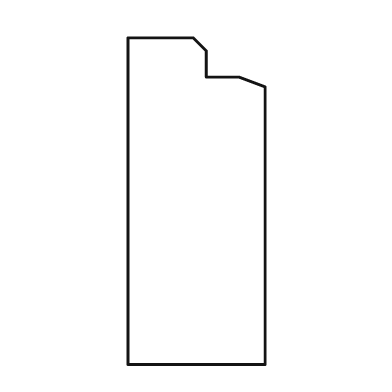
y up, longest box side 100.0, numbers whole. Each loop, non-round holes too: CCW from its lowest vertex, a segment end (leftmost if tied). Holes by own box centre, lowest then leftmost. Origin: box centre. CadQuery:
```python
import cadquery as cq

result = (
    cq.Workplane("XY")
    .moveTo(-21.0, -50.0)
    .lineTo(21.0, -50.0)
    .lineTo(21.0, 35.0)
    .lineTo(13.0, 38.0)
    .lineTo(3.0, 38.0)
    .lineTo(3.0, 46.0)
    .lineTo(-1.0, 50.0)
    .lineTo(-21.0, 50.0)
    .close()
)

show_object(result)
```